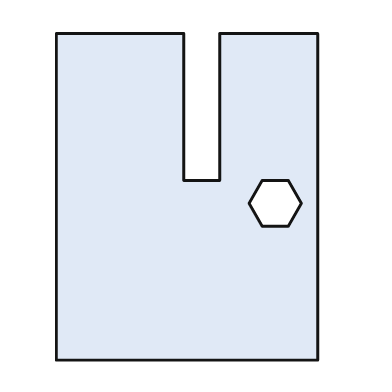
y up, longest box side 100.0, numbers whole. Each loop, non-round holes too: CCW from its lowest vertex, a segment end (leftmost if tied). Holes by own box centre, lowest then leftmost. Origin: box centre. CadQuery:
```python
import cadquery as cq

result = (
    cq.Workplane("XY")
    .moveTo(-40.0, -50.0)
    .lineTo(40.0, -50.0)
    .lineTo(40.0, 50.0)
    .lineTo(10.0, 50.0)
    .lineTo(10.0, 5.0)
    .lineTo(-1.0, 5.0)
    .lineTo(-1.0, 50.0)
    .lineTo(-40.0, 50.0)
    .close()
    .moveTo(23.0, -9.0)
    .lineTo(31.0, -9.0)
    .lineTo(35.0, -2.0)
    .lineTo(31.0, 5.0)
    .lineTo(23.0, 5.0)
    .lineTo(19.0, -2.0)
    .close()
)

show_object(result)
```